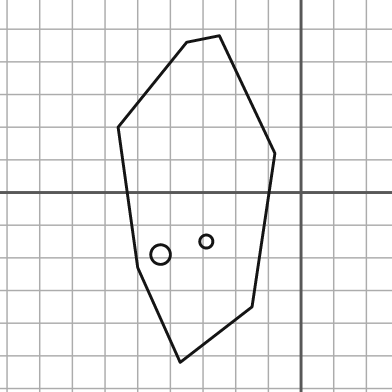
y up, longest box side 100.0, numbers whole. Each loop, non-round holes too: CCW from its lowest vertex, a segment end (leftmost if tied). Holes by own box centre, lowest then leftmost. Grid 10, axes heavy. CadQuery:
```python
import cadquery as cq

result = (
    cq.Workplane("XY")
    .moveTo(-37.0, -52.0)
    .lineTo(-15.0, -35.0)
    .lineTo(-8.0, 12.0)
    .lineTo(-25.0, 48.0)
    .lineTo(-35.0, 46.0)
    .lineTo(-56.0, 20.0)
    .lineTo(-50.0, -23.0)
    .close()
    .moveTo(-43.0, -19.0)
    .circle(3.0)
    .moveTo(-29.0, -15.0)
    .circle(2.0)
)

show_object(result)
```